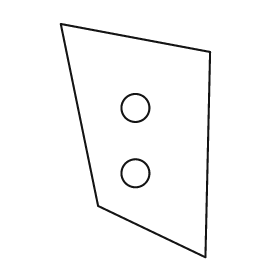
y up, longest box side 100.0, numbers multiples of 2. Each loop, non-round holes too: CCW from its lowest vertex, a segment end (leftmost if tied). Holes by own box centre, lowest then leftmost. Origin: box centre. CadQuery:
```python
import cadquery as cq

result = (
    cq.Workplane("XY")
    .moveTo(30.0, -50.0)
    .lineTo(32.0, 38.0)
    .lineTo(-32.0, 50.0)
    .lineTo(-16.0, -28.0)
    .close()
    .moveTo(0.0, -14.0)
    .circle(6.0)
    .moveTo(0.0, 14.0)
    .circle(6.0)
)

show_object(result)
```